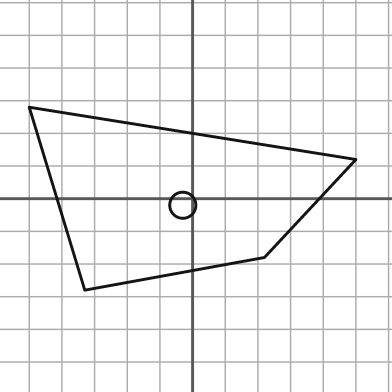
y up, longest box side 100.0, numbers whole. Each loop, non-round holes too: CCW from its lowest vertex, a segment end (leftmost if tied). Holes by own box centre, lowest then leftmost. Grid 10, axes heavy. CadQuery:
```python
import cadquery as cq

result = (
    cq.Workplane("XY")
    .moveTo(-33.0, -28.0)
    .lineTo(22.0, -18.0)
    .lineTo(50.0, 12.0)
    .lineTo(-50.0, 28.0)
    .close()
    .moveTo(-3.0, -2.0)
    .circle(4.0)
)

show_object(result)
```